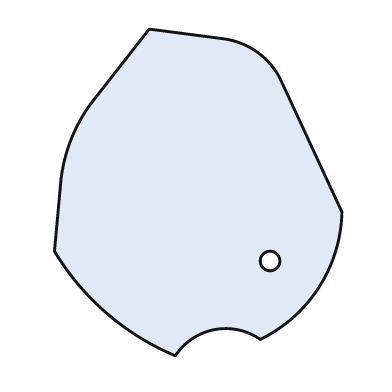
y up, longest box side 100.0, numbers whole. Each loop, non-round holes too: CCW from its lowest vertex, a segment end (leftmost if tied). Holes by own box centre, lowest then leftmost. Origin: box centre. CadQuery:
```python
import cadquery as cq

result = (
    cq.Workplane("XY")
    .moveTo(-7.0, -50.0)
    .threePointArc((5.0, -42.0), (19.0, -45.0))
    .threePointArc((37.0, -29.0), (44.0, -6.0))
    .lineTo(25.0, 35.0)
    .threePointArc((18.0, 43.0), (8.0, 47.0))
    .lineTo(-15.0, 50.0)
    .lineTo(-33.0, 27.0)
    .threePointArc((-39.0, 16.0), (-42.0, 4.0))
    .lineTo(-44.0, -18.0)
    .threePointArc((-28.0, -37.0), (-7.0, -50.0))
    .close()
    .moveTo(22.0, -21.0)
    .circle(3.0)
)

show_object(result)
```